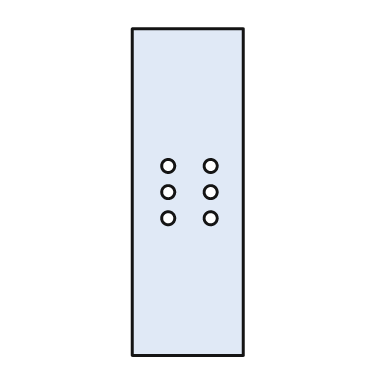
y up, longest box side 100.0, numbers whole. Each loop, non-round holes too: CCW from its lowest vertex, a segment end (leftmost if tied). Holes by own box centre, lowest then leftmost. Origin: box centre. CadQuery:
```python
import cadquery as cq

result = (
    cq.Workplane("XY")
    .moveTo(-17.0, -50.0)
    .lineTo(17.0, -50.0)
    .lineTo(17.0, 50.0)
    .lineTo(-17.0, 50.0)
    .close()
    .moveTo(-6.0, -8.0)
    .circle(2.0)
    .moveTo(7.0, -8.0)
    .circle(2.0)
    .moveTo(-6.0, 0.0)
    .circle(2.0)
    .moveTo(7.0, 0.0)
    .circle(2.0)
    .moveTo(-6.0, 8.0)
    .circle(2.0)
    .moveTo(7.0, 8.0)
    .circle(2.0)
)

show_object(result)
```